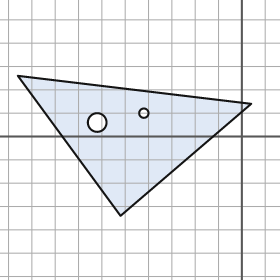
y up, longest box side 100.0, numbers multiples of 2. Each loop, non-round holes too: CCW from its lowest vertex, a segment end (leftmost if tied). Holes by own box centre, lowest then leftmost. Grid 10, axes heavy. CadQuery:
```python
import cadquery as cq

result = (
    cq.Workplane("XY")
    .moveTo(-52.0, -34.0)
    .lineTo(4.0, 14.0)
    .lineTo(-96.0, 26.0)
    .close()
    .moveTo(-62.0, 6.0)
    .circle(4.0)
    .moveTo(-42.0, 10.0)
    .circle(2.0)
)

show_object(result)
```